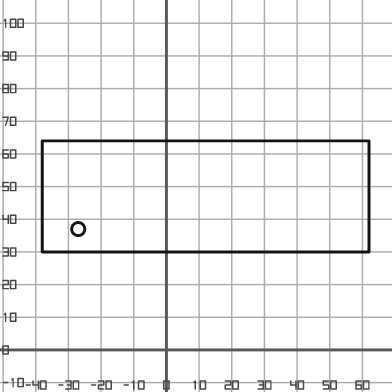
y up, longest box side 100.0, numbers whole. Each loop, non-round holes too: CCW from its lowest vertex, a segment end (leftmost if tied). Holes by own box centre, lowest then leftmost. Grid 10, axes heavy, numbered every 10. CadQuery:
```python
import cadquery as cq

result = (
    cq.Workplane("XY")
    .moveTo(-38.0, 30.0)
    .lineTo(62.0, 30.0)
    .lineTo(62.0, 64.0)
    .lineTo(-38.0, 64.0)
    .close()
    .moveTo(-27.0, 37.0)
    .circle(2.0)
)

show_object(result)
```